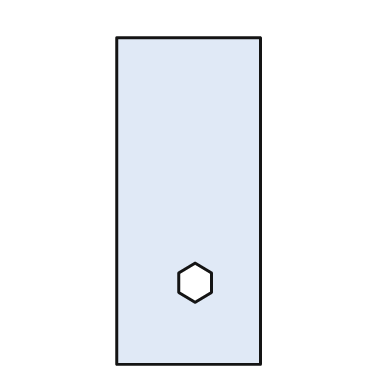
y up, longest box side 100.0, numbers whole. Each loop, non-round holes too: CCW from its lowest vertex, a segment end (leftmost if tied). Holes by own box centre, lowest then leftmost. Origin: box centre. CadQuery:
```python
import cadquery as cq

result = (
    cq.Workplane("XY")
    .moveTo(-22.0, -50.0)
    .lineTo(22.0, -50.0)
    .lineTo(22.0, 50.0)
    .lineTo(-22.0, 50.0)
    .close()
    .moveTo(2.0, -31.0)
    .lineTo(7.0, -28.0)
    .lineTo(7.0, -22.0)
    .lineTo(2.0, -19.0)
    .lineTo(-3.0, -22.0)
    .lineTo(-3.0, -28.0)
    .close()
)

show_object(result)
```